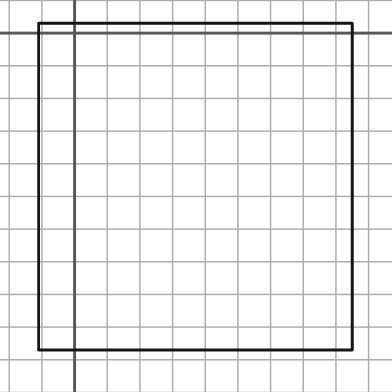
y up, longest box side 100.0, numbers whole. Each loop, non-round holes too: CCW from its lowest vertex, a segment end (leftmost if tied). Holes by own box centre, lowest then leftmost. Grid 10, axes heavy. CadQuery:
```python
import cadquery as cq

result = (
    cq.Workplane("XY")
    .moveTo(-11.0, -97.0)
    .lineTo(85.0, -97.0)
    .lineTo(85.0, 3.0)
    .lineTo(-11.0, 3.0)
    .close()
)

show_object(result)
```